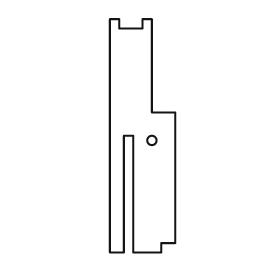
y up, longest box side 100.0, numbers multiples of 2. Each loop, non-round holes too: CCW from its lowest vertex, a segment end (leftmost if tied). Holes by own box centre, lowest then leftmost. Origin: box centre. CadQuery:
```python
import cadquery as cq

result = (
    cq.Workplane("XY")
    .moveTo(-14.0, -50.0)
    .lineTo(-8.0, -50.0)
    .lineTo(-8.0, 0.0)
    .lineTo(-4.0, 0.0)
    .lineTo(-4.0, -50.0)
    .lineTo(8.0, -50.0)
    .lineTo(8.0, -46.0)
    .lineTo(14.0, -46.0)
    .lineTo(14.0, 10.0)
    .lineTo(4.0, 10.0)
    .lineTo(4.0, 50.0)
    .lineTo(0.0, 50.0)
    .lineTo(0.0, 46.0)
    .lineTo(-10.0, 46.0)
    .lineTo(-10.0, 50.0)
    .lineTo(-14.0, 50.0)
    .close()
    .moveTo(4.0, -2.0)
    .circle(2.0)
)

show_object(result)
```